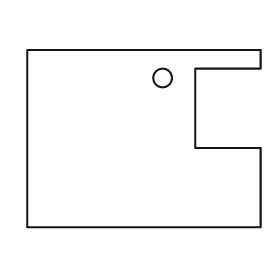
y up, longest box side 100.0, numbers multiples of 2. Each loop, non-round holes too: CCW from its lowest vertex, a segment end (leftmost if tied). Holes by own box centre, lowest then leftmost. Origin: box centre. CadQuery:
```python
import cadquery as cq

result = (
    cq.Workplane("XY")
    .moveTo(-50.0, -38.0)
    .lineTo(50.0, -38.0)
    .lineTo(50.0, -4.0)
    .lineTo(22.0, -4.0)
    .lineTo(22.0, 30.0)
    .lineTo(50.0, 30.0)
    .lineTo(50.0, 38.0)
    .lineTo(-50.0, 38.0)
    .close()
    .moveTo(8.0, 26.0)
    .circle(4.0)
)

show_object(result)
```